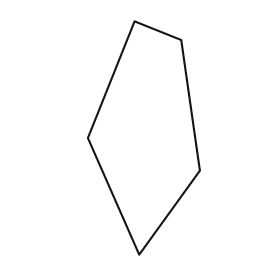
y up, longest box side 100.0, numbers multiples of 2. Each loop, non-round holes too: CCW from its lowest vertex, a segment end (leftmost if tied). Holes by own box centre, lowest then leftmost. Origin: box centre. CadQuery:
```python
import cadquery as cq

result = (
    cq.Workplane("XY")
    .moveTo(-2.0, -50.0)
    .lineTo(24.0, -14.0)
    .lineTo(16.0, 42.0)
    .lineTo(-4.0, 50.0)
    .lineTo(-24.0, 0.0)
    .close()
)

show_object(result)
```